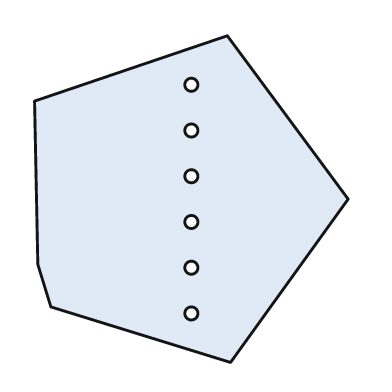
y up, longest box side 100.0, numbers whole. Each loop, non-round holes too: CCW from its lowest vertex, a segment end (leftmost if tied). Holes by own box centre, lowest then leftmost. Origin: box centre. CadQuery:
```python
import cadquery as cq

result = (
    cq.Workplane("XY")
    .moveTo(12.0, -50.0)
    .lineTo(48.0, 0.0)
    .lineTo(11.0, 50.0)
    .lineTo(-48.0, 30.0)
    .lineTo(-47.0, -20.0)
    .lineTo(-43.0, -33.0)
    .close()
    .moveTo(0.0, -35.0)
    .circle(2.0)
    .moveTo(0.0, -21.0)
    .circle(2.0)
    .moveTo(0.0, -7.0)
    .circle(2.0)
    .moveTo(0.0, 7.0)
    .circle(2.0)
    .moveTo(0.0, 21.0)
    .circle(2.0)
    .moveTo(0.0, 35.0)
    .circle(2.0)
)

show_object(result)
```